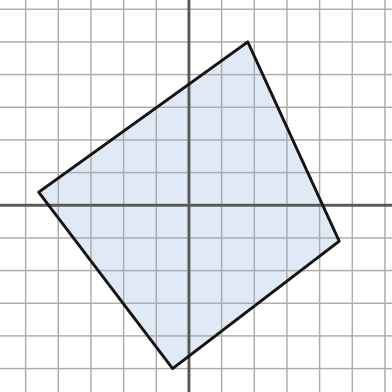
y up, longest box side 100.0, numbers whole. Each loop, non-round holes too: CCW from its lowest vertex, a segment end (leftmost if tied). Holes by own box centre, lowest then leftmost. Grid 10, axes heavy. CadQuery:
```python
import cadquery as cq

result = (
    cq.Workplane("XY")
    .moveTo(-5.0, -50.0)
    .lineTo(46.0, -11.0)
    .lineTo(18.0, 50.0)
    .lineTo(-46.0, 4.0)
    .close()
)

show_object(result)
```